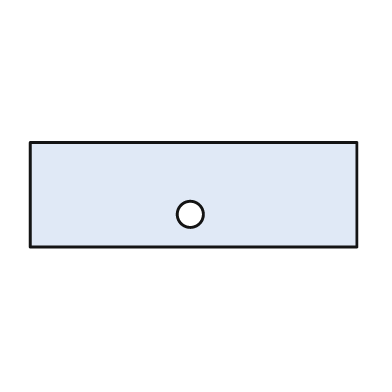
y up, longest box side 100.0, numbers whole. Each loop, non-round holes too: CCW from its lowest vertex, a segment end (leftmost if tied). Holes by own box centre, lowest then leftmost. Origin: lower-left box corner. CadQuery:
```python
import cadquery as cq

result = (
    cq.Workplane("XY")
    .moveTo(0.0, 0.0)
    .lineTo(100.0, 0.0)
    .lineTo(100.0, 32.0)
    .lineTo(0.0, 32.0)
    .close()
    .moveTo(49.0, 10.0)
    .circle(4.0)
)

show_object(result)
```